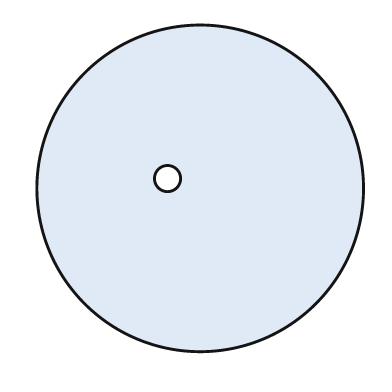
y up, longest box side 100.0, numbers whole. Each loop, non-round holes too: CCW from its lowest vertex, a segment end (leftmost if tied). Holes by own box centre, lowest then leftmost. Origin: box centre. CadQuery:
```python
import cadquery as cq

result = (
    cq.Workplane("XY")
    .moveTo(0.0, 0.0)
    .circle(50.0)
    .moveTo(-10.0, 3.0)
    .circle(4.0)
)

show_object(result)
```